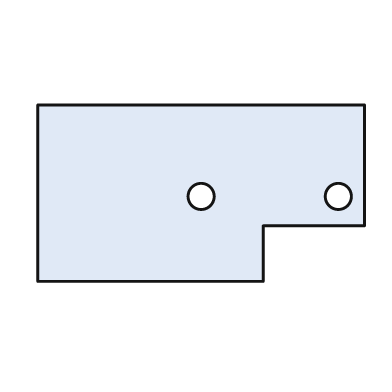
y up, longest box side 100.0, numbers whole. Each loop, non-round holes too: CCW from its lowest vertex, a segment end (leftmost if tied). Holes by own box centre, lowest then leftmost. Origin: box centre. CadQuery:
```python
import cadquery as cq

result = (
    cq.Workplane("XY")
    .moveTo(-50.0, -27.0)
    .lineTo(19.0, -27.0)
    .lineTo(19.0, -10.0)
    .lineTo(50.0, -10.0)
    .lineTo(50.0, 27.0)
    .lineTo(-50.0, 27.0)
    .close()
    .moveTo(0.0, -1.0)
    .circle(4.0)
    .moveTo(42.0, -1.0)
    .circle(4.0)
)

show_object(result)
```